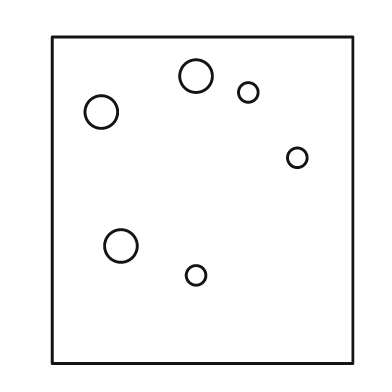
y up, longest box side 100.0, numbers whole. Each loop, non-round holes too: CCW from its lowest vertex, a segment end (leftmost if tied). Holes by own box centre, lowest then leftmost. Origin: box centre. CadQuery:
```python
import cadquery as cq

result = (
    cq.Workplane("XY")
    .moveTo(-46.0, -50.0)
    .lineTo(46.0, -50.0)
    .lineTo(46.0, 50.0)
    .lineTo(-46.0, 50.0)
    .close()
    .moveTo(-2.0, -23.0)
    .circle(3.0)
    .moveTo(-25.0, -14.0)
    .circle(5.0)
    .moveTo(29.0, 13.0)
    .circle(3.0)
    .moveTo(-31.0, 27.0)
    .circle(5.0)
    .moveTo(14.0, 33.0)
    .circle(3.0)
    .moveTo(-2.0, 38.0)
    .circle(5.0)
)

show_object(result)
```